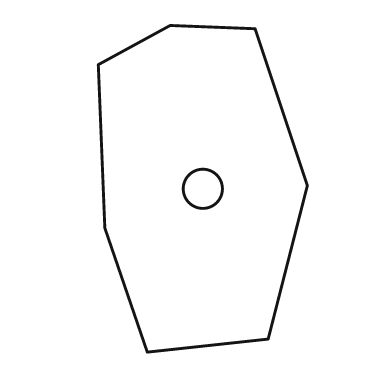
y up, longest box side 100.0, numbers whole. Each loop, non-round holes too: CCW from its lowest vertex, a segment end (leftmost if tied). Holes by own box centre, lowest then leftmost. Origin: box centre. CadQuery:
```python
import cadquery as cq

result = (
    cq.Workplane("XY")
    .moveTo(-17.0, -50.0)
    .lineTo(20.0, -46.0)
    .lineTo(32.0, 1.0)
    .lineTo(16.0, 49.0)
    .lineTo(-10.0, 50.0)
    .lineTo(-32.0, 38.0)
    .lineTo(-30.0, -12.0)
    .close()
    .moveTo(0.0, 0.0)
    .circle(6.0)
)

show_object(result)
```